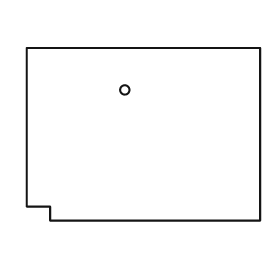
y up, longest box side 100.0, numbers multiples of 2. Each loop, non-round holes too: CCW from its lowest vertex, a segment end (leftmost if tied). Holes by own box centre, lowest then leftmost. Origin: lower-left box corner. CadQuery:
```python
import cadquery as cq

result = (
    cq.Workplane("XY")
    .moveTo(10.0, 0.0)
    .lineTo(100.0, 0.0)
    .lineTo(100.0, 74.0)
    .lineTo(0.0, 74.0)
    .lineTo(0.0, 6.0)
    .lineTo(10.0, 6.0)
    .close()
    .moveTo(42.0, 56.0)
    .circle(2.0)
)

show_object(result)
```